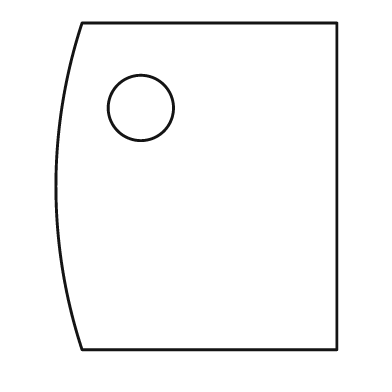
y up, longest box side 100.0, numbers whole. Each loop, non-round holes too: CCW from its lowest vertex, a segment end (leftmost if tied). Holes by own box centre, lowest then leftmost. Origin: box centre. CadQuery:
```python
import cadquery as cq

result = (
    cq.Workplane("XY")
    .moveTo(-35.0, -50.0)
    .lineTo(43.0, -50.0)
    .lineTo(43.0, 50.0)
    .lineTo(-35.0, 50.0)
    .threePointArc((-43.0, 0.0), (-35.0, -50.0))
    .close()
    .moveTo(-17.0, 24.0)
    .circle(10.0)
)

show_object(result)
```